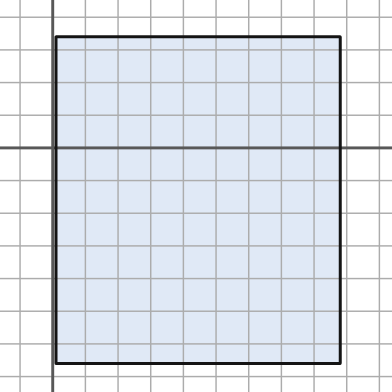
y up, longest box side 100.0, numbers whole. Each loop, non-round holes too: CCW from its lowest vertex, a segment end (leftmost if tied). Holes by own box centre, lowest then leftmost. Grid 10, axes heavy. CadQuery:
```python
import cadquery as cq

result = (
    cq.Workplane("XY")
    .moveTo(1.0, -66.0)
    .lineTo(88.0, -66.0)
    .lineTo(88.0, 34.0)
    .lineTo(1.0, 34.0)
    .close()
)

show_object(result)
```